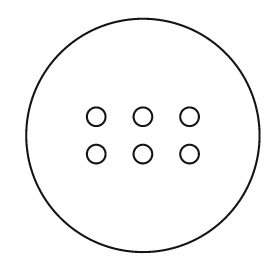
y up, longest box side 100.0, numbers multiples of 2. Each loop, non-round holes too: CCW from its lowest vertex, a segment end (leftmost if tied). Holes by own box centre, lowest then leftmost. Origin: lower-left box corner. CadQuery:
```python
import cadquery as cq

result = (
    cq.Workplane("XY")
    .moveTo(50.0, 50.0)
    .circle(50.0)
    .moveTo(30.0, 42.0)
    .circle(4.0)
    .moveTo(50.0, 42.0)
    .circle(4.0)
    .moveTo(70.0, 42.0)
    .circle(4.0)
    .moveTo(30.0, 58.0)
    .circle(4.0)
    .moveTo(50.0, 58.0)
    .circle(4.0)
    .moveTo(70.0, 58.0)
    .circle(4.0)
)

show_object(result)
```